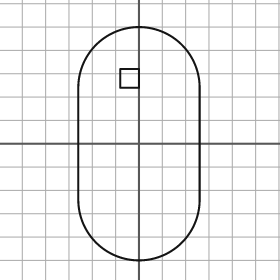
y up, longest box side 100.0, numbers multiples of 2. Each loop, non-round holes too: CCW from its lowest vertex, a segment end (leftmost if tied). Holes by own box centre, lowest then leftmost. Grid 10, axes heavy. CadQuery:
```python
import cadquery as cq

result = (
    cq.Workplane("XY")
    .moveTo(-26.0, -24.0)
    .threePointArc((0.0, -50.0), (26.0, -24.0))
    .lineTo(26.0, 24.0)
    .threePointArc((0.0, 50.0), (-26.0, 24.0))
    .close()
    .moveTo(-8.0, 24.0)
    .lineTo(0.0, 24.0)
    .lineTo(0.0, 32.0)
    .lineTo(-8.0, 32.0)
    .close()
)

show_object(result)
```